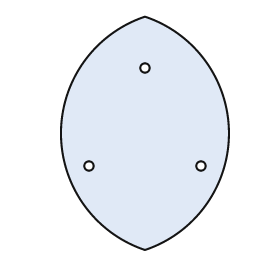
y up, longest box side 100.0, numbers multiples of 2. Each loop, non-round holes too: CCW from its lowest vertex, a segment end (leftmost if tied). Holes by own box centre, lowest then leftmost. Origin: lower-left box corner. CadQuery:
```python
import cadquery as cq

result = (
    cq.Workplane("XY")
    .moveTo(36.0, 0.0)
    .threePointArc((72.0, 50.0), (36.0, 100.0))
    .threePointArc((0.0, 50.0), (36.0, 0.0))
    .close()
    .moveTo(12.0, 36.0)
    .circle(2.0)
    .moveTo(60.0, 36.0)
    .circle(2.0)
    .moveTo(36.0, 78.0)
    .circle(2.0)
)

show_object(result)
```